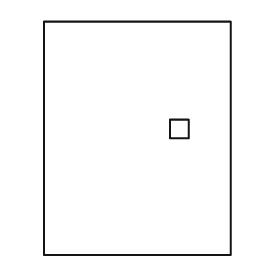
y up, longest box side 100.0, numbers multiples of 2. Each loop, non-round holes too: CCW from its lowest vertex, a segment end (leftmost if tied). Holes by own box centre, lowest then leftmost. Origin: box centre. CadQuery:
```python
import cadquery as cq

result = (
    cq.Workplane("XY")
    .moveTo(-40.0, -50.0)
    .lineTo(40.0, -50.0)
    .lineTo(40.0, 50.0)
    .lineTo(-40.0, 50.0)
    .close()
    .moveTo(14.0, 0.0)
    .lineTo(22.0, 0.0)
    .lineTo(22.0, 8.0)
    .lineTo(14.0, 8.0)
    .close()
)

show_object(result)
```